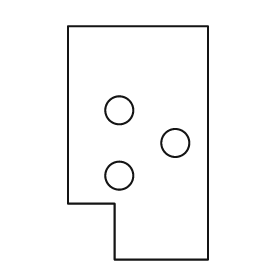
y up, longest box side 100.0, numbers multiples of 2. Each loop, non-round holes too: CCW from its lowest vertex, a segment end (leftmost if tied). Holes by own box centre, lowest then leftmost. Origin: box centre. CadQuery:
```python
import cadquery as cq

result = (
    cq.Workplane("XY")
    .moveTo(-10.0, -50.0)
    .lineTo(30.0, -50.0)
    .lineTo(30.0, 50.0)
    .lineTo(-30.0, 50.0)
    .lineTo(-30.0, -26.0)
    .lineTo(-10.0, -26.0)
    .close()
    .moveTo(-8.0, -14.0)
    .circle(6.0)
    .moveTo(16.0, 0.0)
    .circle(6.0)
    .moveTo(-8.0, 14.0)
    .circle(6.0)
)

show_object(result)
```